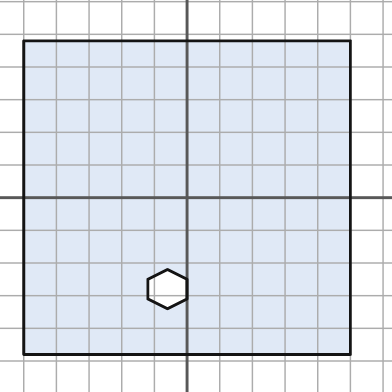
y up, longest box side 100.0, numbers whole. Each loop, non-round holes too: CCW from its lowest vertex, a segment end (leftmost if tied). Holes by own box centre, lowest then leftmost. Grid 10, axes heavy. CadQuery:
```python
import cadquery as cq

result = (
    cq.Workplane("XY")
    .moveTo(-50.0, -48.0)
    .lineTo(50.0, -48.0)
    .lineTo(50.0, 48.0)
    .lineTo(-50.0, 48.0)
    .close()
    .moveTo(-6.0, -34.0)
    .lineTo(0.0, -31.0)
    .lineTo(0.0, -25.0)
    .lineTo(-6.0, -22.0)
    .lineTo(-12.0, -25.0)
    .lineTo(-12.0, -31.0)
    .close()
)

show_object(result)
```